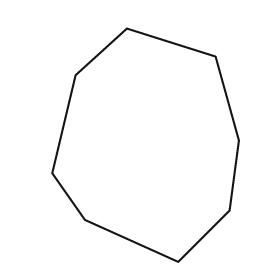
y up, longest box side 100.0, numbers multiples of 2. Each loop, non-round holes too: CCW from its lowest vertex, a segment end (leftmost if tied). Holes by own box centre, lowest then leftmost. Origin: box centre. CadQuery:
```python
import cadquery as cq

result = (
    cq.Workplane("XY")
    .moveTo(14.0, -50.0)
    .lineTo(36.0, -28.0)
    .lineTo(40.0, 2.0)
    .lineTo(30.0, 38.0)
    .lineTo(-8.0, 50.0)
    .lineTo(-30.0, 30.0)
    .lineTo(-40.0, -12.0)
    .lineTo(-26.0, -32.0)
    .close()
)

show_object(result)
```